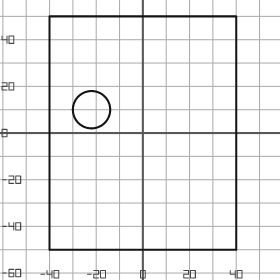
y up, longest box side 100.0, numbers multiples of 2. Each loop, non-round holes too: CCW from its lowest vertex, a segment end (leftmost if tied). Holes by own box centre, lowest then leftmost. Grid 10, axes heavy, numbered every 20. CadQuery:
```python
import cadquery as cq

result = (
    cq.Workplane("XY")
    .moveTo(-40.0, -50.0)
    .lineTo(40.0, -50.0)
    .lineTo(40.0, 50.0)
    .lineTo(-40.0, 50.0)
    .close()
    .moveTo(-22.0, 10.0)
    .circle(8.0)
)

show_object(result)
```